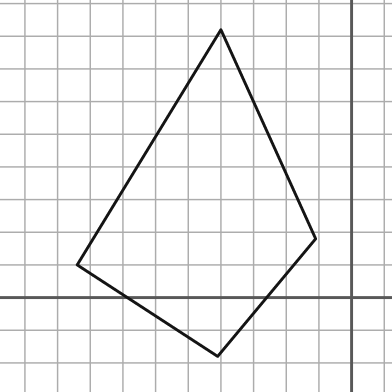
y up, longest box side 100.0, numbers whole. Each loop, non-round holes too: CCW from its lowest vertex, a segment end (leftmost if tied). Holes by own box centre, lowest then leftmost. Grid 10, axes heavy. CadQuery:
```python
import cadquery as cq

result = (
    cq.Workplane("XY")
    .moveTo(-41.0, -18.0)
    .lineTo(-11.0, 18.0)
    .lineTo(-40.0, 82.0)
    .lineTo(-84.0, 10.0)
    .close()
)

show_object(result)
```